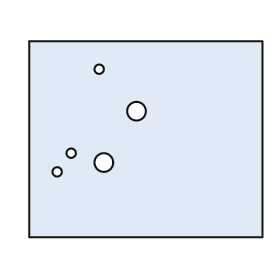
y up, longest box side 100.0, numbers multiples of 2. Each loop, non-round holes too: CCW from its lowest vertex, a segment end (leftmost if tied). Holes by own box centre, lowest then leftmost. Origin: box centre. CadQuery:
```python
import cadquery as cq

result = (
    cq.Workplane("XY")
    .moveTo(-50.0, -42.0)
    .lineTo(50.0, -42.0)
    .lineTo(50.0, 42.0)
    .lineTo(-50.0, 42.0)
    .close()
    .moveTo(-38.0, -14.0)
    .circle(2.0)
    .moveTo(-18.0, -10.0)
    .circle(4.0)
    .moveTo(-32.0, -6.0)
    .circle(2.0)
    .moveTo(-4.0, 12.0)
    .circle(4.0)
    .moveTo(-20.0, 30.0)
    .circle(2.0)
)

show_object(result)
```